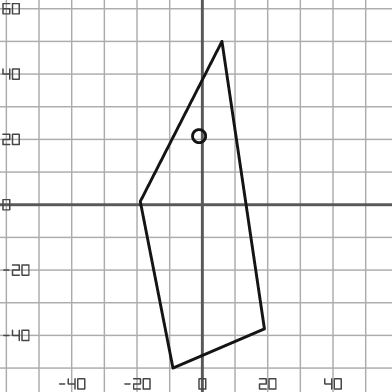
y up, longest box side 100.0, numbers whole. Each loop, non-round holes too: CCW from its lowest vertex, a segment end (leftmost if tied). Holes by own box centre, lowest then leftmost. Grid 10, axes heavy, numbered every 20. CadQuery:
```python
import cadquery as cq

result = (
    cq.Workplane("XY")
    .moveTo(-9.0, -50.0)
    .lineTo(19.0, -38.0)
    .lineTo(6.0, 50.0)
    .lineTo(-19.0, 1.0)
    .close()
    .moveTo(-1.0, 21.0)
    .circle(2.0)
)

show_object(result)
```